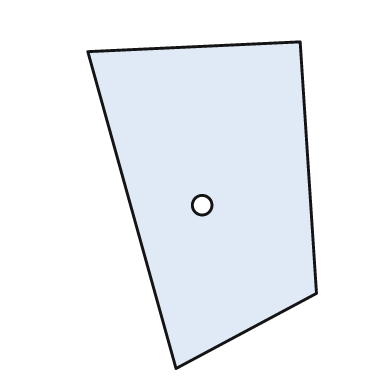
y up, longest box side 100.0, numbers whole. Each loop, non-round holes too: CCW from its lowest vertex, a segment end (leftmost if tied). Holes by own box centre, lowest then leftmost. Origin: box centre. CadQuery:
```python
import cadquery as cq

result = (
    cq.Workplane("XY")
    .moveTo(-8.0, -50.0)
    .lineTo(35.0, -27.0)
    .lineTo(30.0, 50.0)
    .lineTo(-35.0, 47.0)
    .close()
    .moveTo(0.0, 0.0)
    .circle(3.0)
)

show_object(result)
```